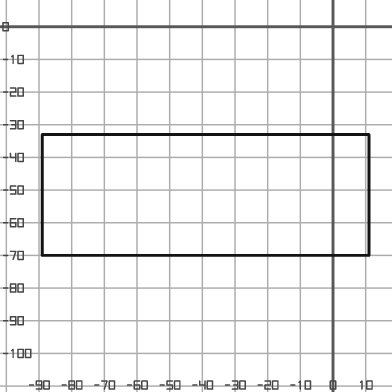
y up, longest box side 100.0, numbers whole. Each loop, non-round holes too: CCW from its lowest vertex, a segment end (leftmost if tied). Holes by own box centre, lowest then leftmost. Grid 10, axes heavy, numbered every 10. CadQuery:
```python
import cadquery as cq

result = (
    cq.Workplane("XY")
    .moveTo(-89.0, -70.0)
    .lineTo(11.0, -70.0)
    .lineTo(11.0, -33.0)
    .lineTo(-89.0, -33.0)
    .close()
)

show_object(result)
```